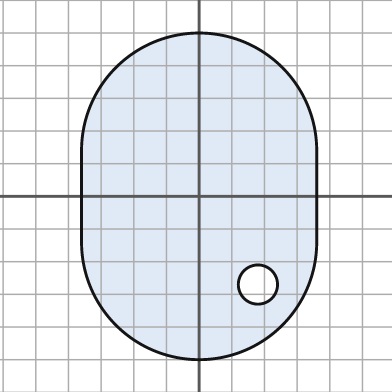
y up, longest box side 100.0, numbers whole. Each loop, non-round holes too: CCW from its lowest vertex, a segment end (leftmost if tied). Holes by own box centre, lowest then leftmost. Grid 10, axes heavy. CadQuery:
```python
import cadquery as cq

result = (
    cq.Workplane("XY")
    .moveTo(-36.0, -14.0)
    .threePointArc((0.0, -50.0), (36.0, -14.0))
    .lineTo(36.0, 14.0)
    .threePointArc((0.0, 50.0), (-36.0, 14.0))
    .close()
    .moveTo(18.0, -27.0)
    .circle(6.0)
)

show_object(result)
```